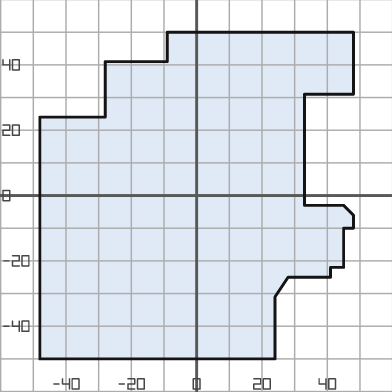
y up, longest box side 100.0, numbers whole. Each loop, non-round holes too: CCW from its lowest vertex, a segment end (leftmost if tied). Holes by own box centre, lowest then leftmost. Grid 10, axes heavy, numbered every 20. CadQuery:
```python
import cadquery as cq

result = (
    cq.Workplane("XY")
    .moveTo(-48.0, -50.0)
    .lineTo(24.0, -50.0)
    .lineTo(24.0, -31.0)
    .lineTo(28.0, -25.0)
    .lineTo(41.0, -25.0)
    .lineTo(41.0, -22.0)
    .lineTo(45.0, -22.0)
    .lineTo(45.0, -10.0)
    .lineTo(48.0, -10.0)
    .lineTo(48.0, -6.0)
    .lineTo(45.0, -3.0)
    .lineTo(33.0, -3.0)
    .lineTo(33.0, 31.0)
    .lineTo(48.0, 31.0)
    .lineTo(48.0, 50.0)
    .lineTo(-9.0, 50.0)
    .lineTo(-9.0, 41.0)
    .lineTo(-28.0, 41.0)
    .lineTo(-28.0, 24.0)
    .lineTo(-48.0, 24.0)
    .close()
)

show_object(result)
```